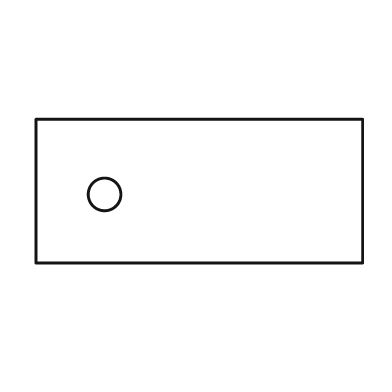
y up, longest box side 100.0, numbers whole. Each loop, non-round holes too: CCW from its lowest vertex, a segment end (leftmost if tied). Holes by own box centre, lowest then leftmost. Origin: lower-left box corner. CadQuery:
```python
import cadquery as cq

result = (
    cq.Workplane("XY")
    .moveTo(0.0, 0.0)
    .lineTo(100.0, 0.0)
    .lineTo(100.0, 44.0)
    .lineTo(0.0, 44.0)
    .close()
    .moveTo(21.0, 21.0)
    .circle(5.0)
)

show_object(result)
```